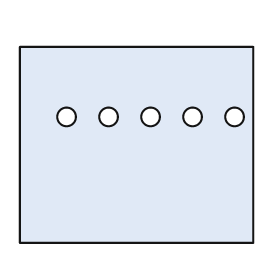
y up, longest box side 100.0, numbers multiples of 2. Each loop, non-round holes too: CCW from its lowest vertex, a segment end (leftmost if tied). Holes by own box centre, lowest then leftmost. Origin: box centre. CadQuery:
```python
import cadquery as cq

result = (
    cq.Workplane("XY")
    .moveTo(-50.0, -42.0)
    .lineTo(50.0, -42.0)
    .lineTo(50.0, 42.0)
    .lineTo(-50.0, 42.0)
    .close()
    .moveTo(-30.0, 12.0)
    .circle(4.0)
    .moveTo(-12.0, 12.0)
    .circle(4.0)
    .moveTo(6.0, 12.0)
    .circle(4.0)
    .moveTo(24.0, 12.0)
    .circle(4.0)
    .moveTo(42.0, 12.0)
    .circle(4.0)
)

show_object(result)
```